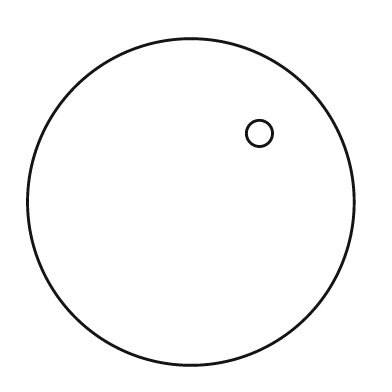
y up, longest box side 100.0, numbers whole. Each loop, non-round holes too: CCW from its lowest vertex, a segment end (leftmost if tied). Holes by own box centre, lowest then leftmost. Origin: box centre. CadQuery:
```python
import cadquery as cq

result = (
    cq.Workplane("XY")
    .moveTo(0.0, 0.0)
    .circle(50.0)
    .moveTo(21.0, 21.0)
    .circle(4.0)
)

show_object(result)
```